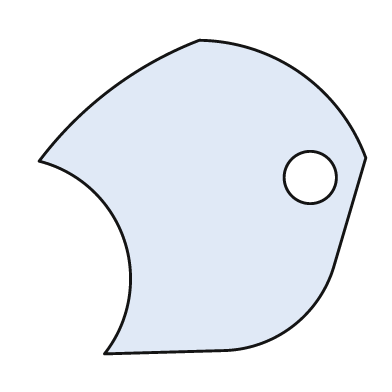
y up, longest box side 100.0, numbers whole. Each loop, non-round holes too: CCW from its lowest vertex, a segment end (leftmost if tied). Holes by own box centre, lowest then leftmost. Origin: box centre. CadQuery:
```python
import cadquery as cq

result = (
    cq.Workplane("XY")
    .moveTo(-30.0, -48.0)
    .lineTo(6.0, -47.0)
    .threePointArc((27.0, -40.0), (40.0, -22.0))
    .lineTo(50.0, 12.0)
    .threePointArc((30.0, 38.0), (-1.0, 48.0))
    .threePointArc((-28.0, 33.0), (-50.0, 11.0))
    .threePointArc((-24.0, -13.0), (-30.0, -48.0))
    .close()
    .moveTo(33.0, 6.0)
    .circle(8.0)
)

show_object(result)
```